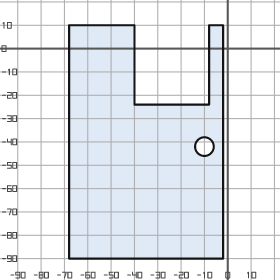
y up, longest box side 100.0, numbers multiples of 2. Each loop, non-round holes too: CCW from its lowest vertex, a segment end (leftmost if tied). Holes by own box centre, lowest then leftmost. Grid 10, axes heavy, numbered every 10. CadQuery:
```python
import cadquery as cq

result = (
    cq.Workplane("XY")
    .moveTo(-68.0, -90.0)
    .lineTo(-2.0, -90.0)
    .lineTo(-2.0, 10.0)
    .lineTo(-8.0, 10.0)
    .lineTo(-8.0, -24.0)
    .lineTo(-40.0, -24.0)
    .lineTo(-40.0, 10.0)
    .lineTo(-68.0, 10.0)
    .close()
    .moveTo(-10.0, -42.0)
    .circle(4.0)
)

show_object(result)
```